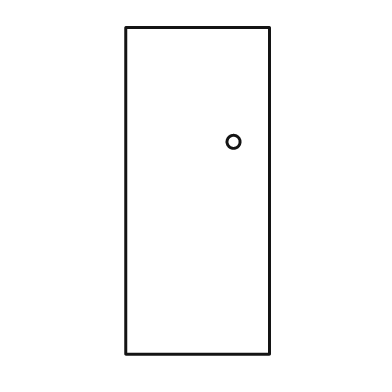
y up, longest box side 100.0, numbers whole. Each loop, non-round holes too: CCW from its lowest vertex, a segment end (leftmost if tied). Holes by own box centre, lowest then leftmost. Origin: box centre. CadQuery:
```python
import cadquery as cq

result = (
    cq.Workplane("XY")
    .moveTo(-22.0, -50.0)
    .lineTo(22.0, -50.0)
    .lineTo(22.0, 50.0)
    .lineTo(-22.0, 50.0)
    .close()
    .moveTo(11.0, 15.0)
    .circle(2.0)
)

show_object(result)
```